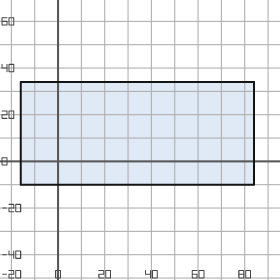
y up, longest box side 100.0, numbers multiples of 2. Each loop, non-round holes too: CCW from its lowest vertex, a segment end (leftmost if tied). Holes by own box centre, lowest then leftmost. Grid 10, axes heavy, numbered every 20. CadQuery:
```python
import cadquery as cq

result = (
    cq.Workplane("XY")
    .moveTo(-16.0, -10.0)
    .lineTo(84.0, -10.0)
    .lineTo(84.0, 34.0)
    .lineTo(-16.0, 34.0)
    .close()
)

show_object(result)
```